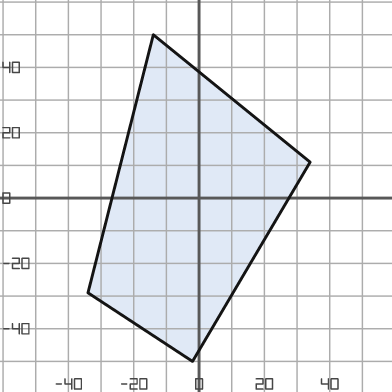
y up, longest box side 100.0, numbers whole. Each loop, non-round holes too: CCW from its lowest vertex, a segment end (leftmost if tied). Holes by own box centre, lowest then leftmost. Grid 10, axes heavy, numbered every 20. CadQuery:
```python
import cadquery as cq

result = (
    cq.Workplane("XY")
    .moveTo(-2.0, -50.0)
    .lineTo(34.0, 11.0)
    .lineTo(-14.0, 50.0)
    .lineTo(-34.0, -29.0)
    .close()
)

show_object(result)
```